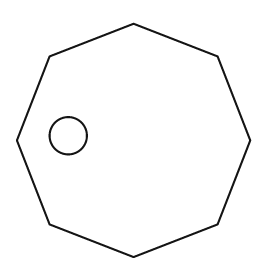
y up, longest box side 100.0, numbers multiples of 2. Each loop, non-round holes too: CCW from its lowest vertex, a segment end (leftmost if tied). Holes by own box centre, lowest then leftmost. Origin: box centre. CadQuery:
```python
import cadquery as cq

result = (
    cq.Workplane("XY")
    .moveTo(0.0, -50.0)
    .lineTo(36.0, -36.0)
    .lineTo(50.0, 0.0)
    .lineTo(36.0, 36.0)
    .lineTo(0.0, 50.0)
    .lineTo(-36.0, 36.0)
    .lineTo(-50.0, 0.0)
    .lineTo(-36.0, -36.0)
    .close()
    .moveTo(-28.0, 2.0)
    .circle(8.0)
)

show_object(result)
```